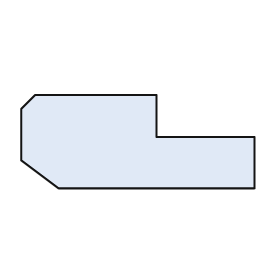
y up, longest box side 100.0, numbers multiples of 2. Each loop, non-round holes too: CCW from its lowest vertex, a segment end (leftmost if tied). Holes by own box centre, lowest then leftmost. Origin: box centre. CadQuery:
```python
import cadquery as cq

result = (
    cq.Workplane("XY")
    .moveTo(-34.0, -20.0)
    .lineTo(50.0, -20.0)
    .lineTo(50.0, 2.0)
    .lineTo(8.0, 2.0)
    .lineTo(8.0, 20.0)
    .lineTo(-44.0, 20.0)
    .lineTo(-50.0, 14.0)
    .lineTo(-50.0, -8.0)
    .close()
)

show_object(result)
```